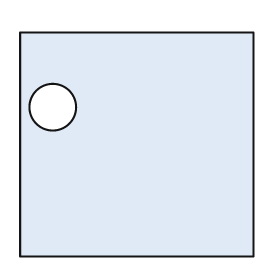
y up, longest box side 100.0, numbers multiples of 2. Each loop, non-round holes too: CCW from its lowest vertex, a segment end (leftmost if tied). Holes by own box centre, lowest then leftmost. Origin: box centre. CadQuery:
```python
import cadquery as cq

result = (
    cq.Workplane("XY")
    .moveTo(-50.0, -48.0)
    .lineTo(50.0, -48.0)
    .lineTo(50.0, 48.0)
    .lineTo(-50.0, 48.0)
    .close()
    .moveTo(-36.0, 16.0)
    .circle(10.0)
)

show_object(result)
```